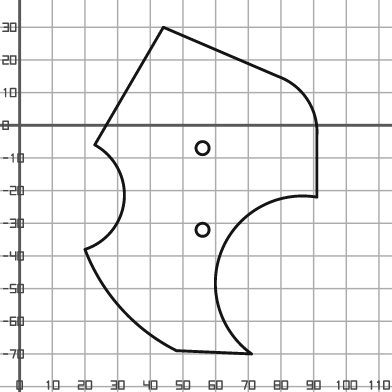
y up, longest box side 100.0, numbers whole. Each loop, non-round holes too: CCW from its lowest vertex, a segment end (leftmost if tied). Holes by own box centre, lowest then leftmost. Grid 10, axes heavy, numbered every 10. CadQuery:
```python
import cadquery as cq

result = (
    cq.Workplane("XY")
    .moveTo(71.0, -70.0)
    .threePointArc((62.0, -38.0), (91.0, -22.0))
    .lineTo(91.0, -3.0)
    .threePointArc((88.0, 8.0), (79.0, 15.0))
    .lineTo(44.0, 30.0)
    .lineTo(23.0, -6.0)
    .threePointArc((32.0, -23.0), (20.0, -38.0))
    .threePointArc((31.0, -56.0), (48.0, -69.0))
    .close()
    .moveTo(56.0, -32.0)
    .circle(2.0)
    .moveTo(56.0, -7.0)
    .circle(2.0)
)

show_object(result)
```